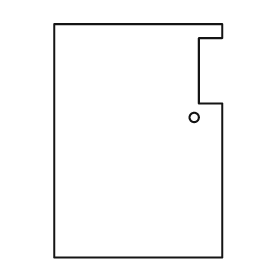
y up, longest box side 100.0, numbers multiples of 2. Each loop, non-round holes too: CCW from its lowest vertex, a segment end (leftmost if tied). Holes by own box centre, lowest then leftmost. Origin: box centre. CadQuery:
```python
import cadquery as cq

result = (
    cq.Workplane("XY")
    .moveTo(-36.0, -50.0)
    .lineTo(36.0, -50.0)
    .lineTo(36.0, 16.0)
    .lineTo(26.0, 16.0)
    .lineTo(26.0, 44.0)
    .lineTo(36.0, 44.0)
    .lineTo(36.0, 50.0)
    .lineTo(-36.0, 50.0)
    .close()
    .moveTo(24.0, 10.0)
    .circle(2.0)
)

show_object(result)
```